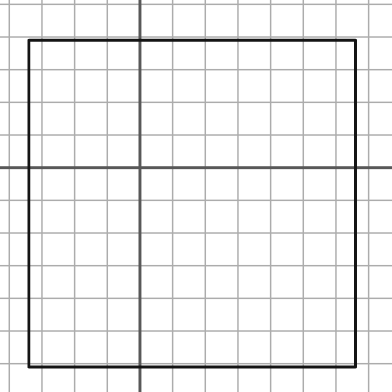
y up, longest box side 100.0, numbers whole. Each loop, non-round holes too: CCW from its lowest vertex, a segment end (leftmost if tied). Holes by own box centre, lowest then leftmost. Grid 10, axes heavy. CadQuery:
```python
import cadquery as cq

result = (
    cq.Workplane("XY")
    .moveTo(-34.0, -61.0)
    .lineTo(66.0, -61.0)
    .lineTo(66.0, 39.0)
    .lineTo(-34.0, 39.0)
    .close()
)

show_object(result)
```